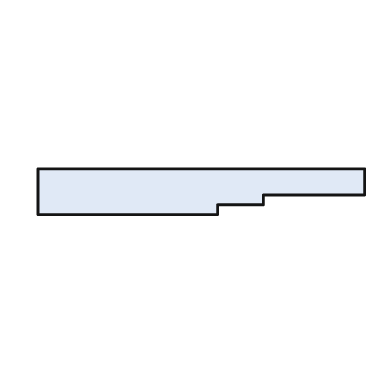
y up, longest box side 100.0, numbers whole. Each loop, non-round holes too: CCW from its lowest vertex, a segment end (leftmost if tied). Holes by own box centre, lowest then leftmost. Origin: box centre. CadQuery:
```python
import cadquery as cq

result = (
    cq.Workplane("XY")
    .moveTo(-50.0, -7.0)
    .lineTo(5.0, -7.0)
    .lineTo(5.0, -4.0)
    .lineTo(19.0, -4.0)
    .lineTo(19.0, -1.0)
    .lineTo(50.0, -1.0)
    .lineTo(50.0, 7.0)
    .lineTo(-50.0, 7.0)
    .close()
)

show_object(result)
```